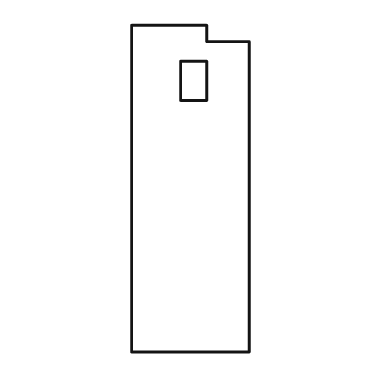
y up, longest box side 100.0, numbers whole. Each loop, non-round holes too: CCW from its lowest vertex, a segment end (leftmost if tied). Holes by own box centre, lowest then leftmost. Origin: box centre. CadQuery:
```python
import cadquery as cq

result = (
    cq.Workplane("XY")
    .moveTo(-18.0, -50.0)
    .lineTo(18.0, -50.0)
    .lineTo(18.0, 45.0)
    .lineTo(5.0, 45.0)
    .lineTo(5.0, 50.0)
    .lineTo(-18.0, 50.0)
    .close()
    .moveTo(-3.0, 27.0)
    .lineTo(5.0, 27.0)
    .lineTo(5.0, 39.0)
    .lineTo(-3.0, 39.0)
    .close()
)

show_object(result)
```